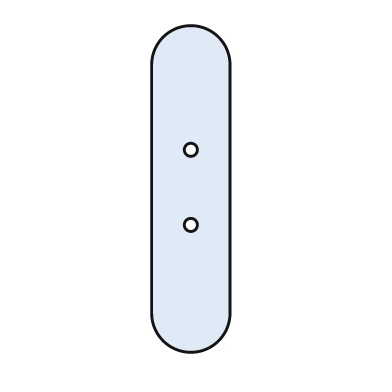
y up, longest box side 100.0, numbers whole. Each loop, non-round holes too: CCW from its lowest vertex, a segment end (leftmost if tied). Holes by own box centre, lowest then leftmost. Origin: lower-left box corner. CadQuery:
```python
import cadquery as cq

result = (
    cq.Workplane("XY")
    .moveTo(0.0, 12.0)
    .threePointArc((12.0, 0.0), (24.0, 12.0))
    .lineTo(24.0, 88.0)
    .threePointArc((12.0, 100.0), (0.0, 88.0))
    .close()
    .moveTo(12.0, 39.0)
    .circle(2.0)
    .moveTo(12.0, 62.0)
    .circle(2.0)
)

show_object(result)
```